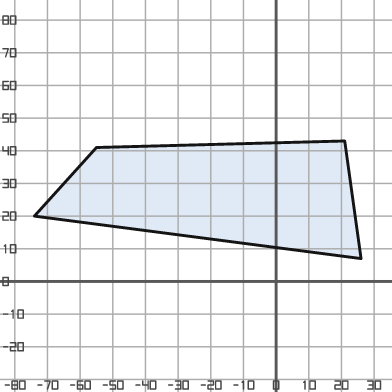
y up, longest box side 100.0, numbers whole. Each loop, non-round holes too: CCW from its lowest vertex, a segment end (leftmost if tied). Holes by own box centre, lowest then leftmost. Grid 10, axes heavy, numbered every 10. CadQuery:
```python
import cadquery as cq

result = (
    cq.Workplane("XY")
    .moveTo(26.0, 7.0)
    .lineTo(21.0, 43.0)
    .lineTo(-55.0, 41.0)
    .lineTo(-74.0, 20.0)
    .close()
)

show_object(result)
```